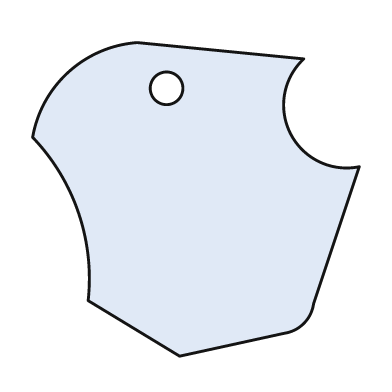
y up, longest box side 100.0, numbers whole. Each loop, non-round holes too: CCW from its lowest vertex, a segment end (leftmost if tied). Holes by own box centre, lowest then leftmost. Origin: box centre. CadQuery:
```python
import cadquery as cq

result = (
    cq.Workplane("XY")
    .moveTo(-5.0, -48.0)
    .lineTo(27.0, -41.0)
    .threePointArc((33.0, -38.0), (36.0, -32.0))
    .lineTo(50.0, 10.0)
    .threePointArc((29.0, 20.0), (33.0, 43.0))
    .lineTo(-18.0, 48.0)
    .threePointArc((-39.0, 39.0), (-50.0, 19.0))
    .threePointArc((-36.0, -4.0), (-33.0, -31.0))
    .close()
    .moveTo(-9.0, 34.0)
    .circle(5.0)
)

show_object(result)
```